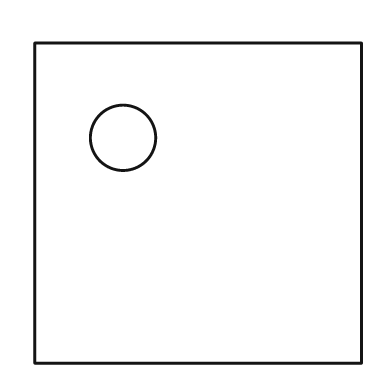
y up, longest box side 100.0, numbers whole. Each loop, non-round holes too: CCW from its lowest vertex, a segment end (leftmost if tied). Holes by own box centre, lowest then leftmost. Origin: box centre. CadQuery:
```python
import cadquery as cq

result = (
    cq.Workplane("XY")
    .moveTo(-50.0, -49.0)
    .lineTo(50.0, -49.0)
    .lineTo(50.0, 49.0)
    .lineTo(-50.0, 49.0)
    .close()
    .moveTo(-23.0, 20.0)
    .circle(10.0)
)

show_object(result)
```